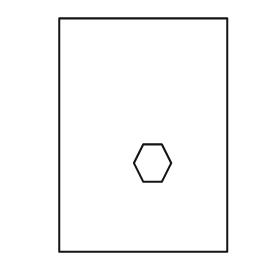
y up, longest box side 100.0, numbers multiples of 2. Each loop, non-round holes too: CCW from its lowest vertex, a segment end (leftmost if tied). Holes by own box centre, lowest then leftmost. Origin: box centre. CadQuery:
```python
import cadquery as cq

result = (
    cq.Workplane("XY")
    .moveTo(-36.0, -50.0)
    .lineTo(36.0, -50.0)
    .lineTo(36.0, 50.0)
    .lineTo(-36.0, 50.0)
    .close()
    .moveTo(0.0, -20.0)
    .lineTo(8.0, -20.0)
    .lineTo(12.0, -12.0)
    .lineTo(8.0, -4.0)
    .lineTo(0.0, -4.0)
    .lineTo(-4.0, -12.0)
    .close()
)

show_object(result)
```